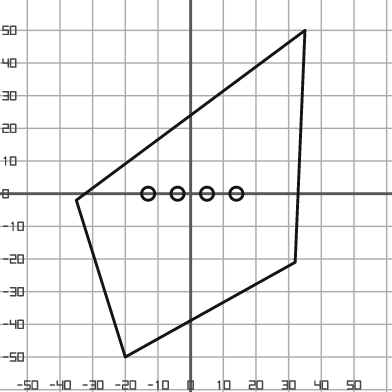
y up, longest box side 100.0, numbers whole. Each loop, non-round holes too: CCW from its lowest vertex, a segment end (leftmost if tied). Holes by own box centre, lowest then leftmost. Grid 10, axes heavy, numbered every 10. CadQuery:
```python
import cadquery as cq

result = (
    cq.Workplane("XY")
    .moveTo(-20.0, -50.0)
    .lineTo(32.0, -21.0)
    .lineTo(35.0, 50.0)
    .lineTo(-35.0, -2.0)
    .close()
    .moveTo(-13.0, 0.0)
    .circle(2.0)
    .moveTo(-4.0, 0.0)
    .circle(2.0)
    .moveTo(5.0, 0.0)
    .circle(2.0)
    .moveTo(14.0, 0.0)
    .circle(2.0)
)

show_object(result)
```